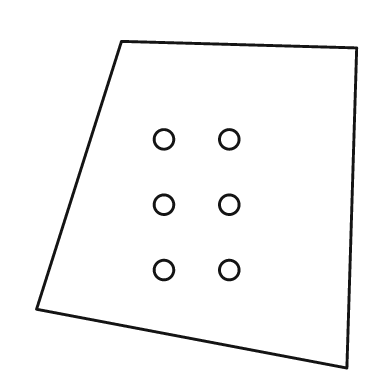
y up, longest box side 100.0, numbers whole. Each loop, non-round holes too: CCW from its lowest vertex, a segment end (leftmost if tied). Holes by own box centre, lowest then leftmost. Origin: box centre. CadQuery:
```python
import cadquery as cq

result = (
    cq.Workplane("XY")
    .moveTo(46.0, -50.0)
    .lineTo(49.0, 48.0)
    .lineTo(-23.0, 50.0)
    .lineTo(-49.0, -32.0)
    .close()
    .moveTo(-10.0, -20.0)
    .circle(3.0)
    .moveTo(10.0, -20.0)
    .circle(3.0)
    .moveTo(-10.0, 0.0)
    .circle(3.0)
    .moveTo(10.0, 0.0)
    .circle(3.0)
    .moveTo(-10.0, 20.0)
    .circle(3.0)
    .moveTo(10.0, 20.0)
    .circle(3.0)
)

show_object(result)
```